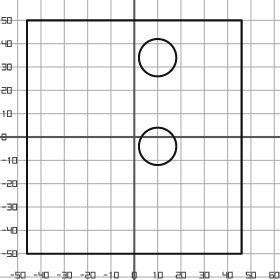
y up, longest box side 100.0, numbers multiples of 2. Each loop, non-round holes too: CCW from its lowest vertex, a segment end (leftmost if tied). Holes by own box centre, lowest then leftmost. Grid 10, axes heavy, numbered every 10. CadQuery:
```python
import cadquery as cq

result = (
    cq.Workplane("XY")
    .moveTo(-46.0, -50.0)
    .lineTo(46.0, -50.0)
    .lineTo(46.0, 50.0)
    .lineTo(-46.0, 50.0)
    .close()
    .moveTo(10.0, -4.0)
    .circle(8.0)
    .moveTo(10.0, 34.0)
    .circle(8.0)
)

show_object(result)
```